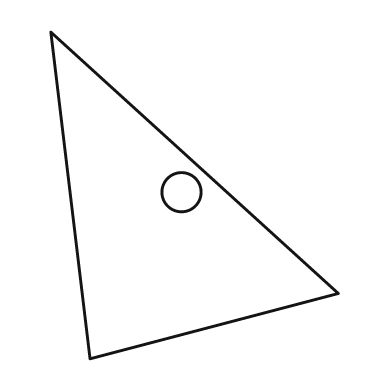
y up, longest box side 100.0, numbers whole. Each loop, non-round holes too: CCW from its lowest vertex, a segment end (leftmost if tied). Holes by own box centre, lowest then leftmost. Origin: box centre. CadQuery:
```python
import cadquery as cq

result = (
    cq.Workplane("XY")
    .moveTo(-32.0, -50.0)
    .lineTo(44.0, -30.0)
    .lineTo(-44.0, 50.0)
    .close()
    .moveTo(-4.0, 1.0)
    .circle(6.0)
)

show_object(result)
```